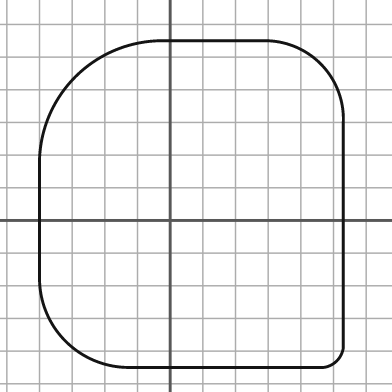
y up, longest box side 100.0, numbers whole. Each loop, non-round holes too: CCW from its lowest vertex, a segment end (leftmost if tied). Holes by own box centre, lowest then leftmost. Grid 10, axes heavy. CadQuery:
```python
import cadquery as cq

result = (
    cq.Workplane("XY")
    .moveTo(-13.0, -45.0)
    .lineTo(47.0, -45.0)
    .threePointArc((51.0, -43.0), (53.0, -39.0))
    .lineTo(53.0, 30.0)
    .threePointArc((46.0, 48.0), (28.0, 55.0))
    .lineTo(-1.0, 55.0)
    .threePointArc((-29.0, 44.0), (-40.0, 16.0))
    .lineTo(-40.0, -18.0)
    .threePointArc((-32.0, -37.0), (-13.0, -45.0))
    .close()
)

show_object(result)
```